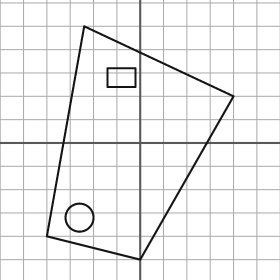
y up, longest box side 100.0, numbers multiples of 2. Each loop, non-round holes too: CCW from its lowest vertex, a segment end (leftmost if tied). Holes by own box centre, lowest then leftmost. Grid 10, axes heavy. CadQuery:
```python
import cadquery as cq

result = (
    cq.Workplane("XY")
    .moveTo(0.0, -50.0)
    .lineTo(40.0, 20.0)
    .lineTo(-24.0, 50.0)
    .lineTo(-40.0, -40.0)
    .close()
    .moveTo(-26.0, -32.0)
    .circle(6.0)
    .moveTo(-14.0, 24.0)
    .lineTo(-2.0, 24.0)
    .lineTo(-2.0, 32.0)
    .lineTo(-14.0, 32.0)
    .close()
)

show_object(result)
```